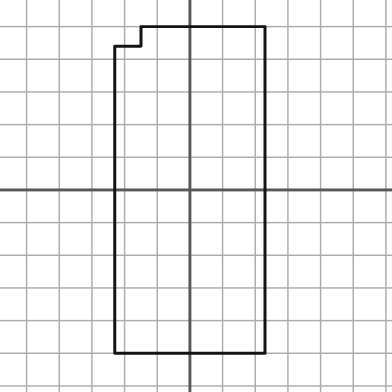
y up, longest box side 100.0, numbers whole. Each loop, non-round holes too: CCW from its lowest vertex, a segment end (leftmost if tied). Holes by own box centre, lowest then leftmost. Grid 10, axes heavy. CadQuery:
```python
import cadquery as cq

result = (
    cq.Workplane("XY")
    .moveTo(-23.0, -50.0)
    .lineTo(23.0, -50.0)
    .lineTo(23.0, 50.0)
    .lineTo(-15.0, 50.0)
    .lineTo(-15.0, 44.0)
    .lineTo(-23.0, 44.0)
    .close()
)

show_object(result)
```